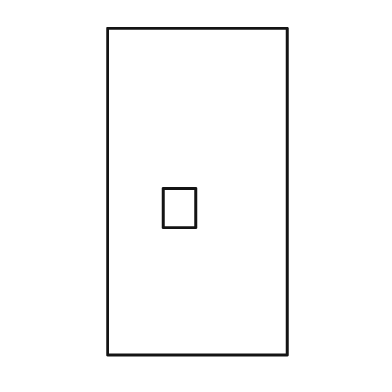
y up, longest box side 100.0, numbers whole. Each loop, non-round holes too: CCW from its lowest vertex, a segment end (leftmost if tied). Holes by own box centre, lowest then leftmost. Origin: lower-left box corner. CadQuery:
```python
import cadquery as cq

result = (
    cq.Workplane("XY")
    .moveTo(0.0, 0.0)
    .lineTo(55.0, 0.0)
    .lineTo(55.0, 100.0)
    .lineTo(0.0, 100.0)
    .close()
    .moveTo(17.0, 39.0)
    .lineTo(27.0, 39.0)
    .lineTo(27.0, 51.0)
    .lineTo(17.0, 51.0)
    .close()
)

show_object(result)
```